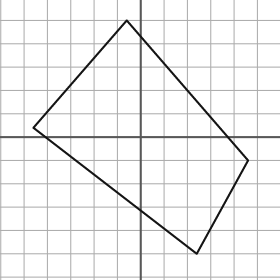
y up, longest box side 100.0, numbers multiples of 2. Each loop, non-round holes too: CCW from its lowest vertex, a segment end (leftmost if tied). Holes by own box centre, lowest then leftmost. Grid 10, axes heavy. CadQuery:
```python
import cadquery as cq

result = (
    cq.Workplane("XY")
    .moveTo(24.0, -50.0)
    .lineTo(46.0, -10.0)
    .lineTo(-6.0, 50.0)
    .lineTo(-46.0, 4.0)
    .close()
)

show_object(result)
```